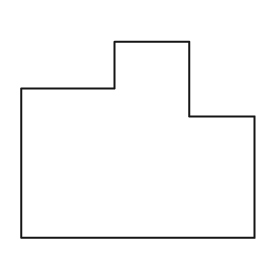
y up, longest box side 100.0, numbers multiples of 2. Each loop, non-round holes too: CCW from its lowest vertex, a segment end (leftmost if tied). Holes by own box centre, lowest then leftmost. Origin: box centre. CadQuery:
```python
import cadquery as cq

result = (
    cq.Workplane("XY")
    .moveTo(-50.0, -42.0)
    .lineTo(50.0, -42.0)
    .lineTo(50.0, 10.0)
    .lineTo(22.0, 10.0)
    .lineTo(22.0, 42.0)
    .lineTo(-10.0, 42.0)
    .lineTo(-10.0, 22.0)
    .lineTo(-50.0, 22.0)
    .close()
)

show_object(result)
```